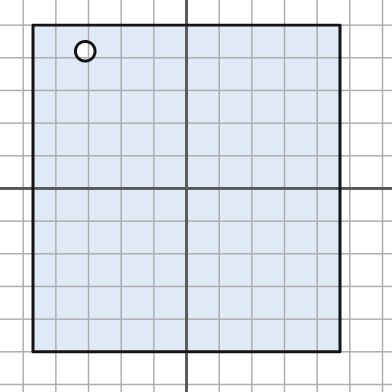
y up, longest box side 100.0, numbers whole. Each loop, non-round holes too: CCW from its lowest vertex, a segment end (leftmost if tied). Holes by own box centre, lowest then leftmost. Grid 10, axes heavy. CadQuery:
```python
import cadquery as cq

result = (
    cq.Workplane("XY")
    .moveTo(-47.0, -50.0)
    .lineTo(47.0, -50.0)
    .lineTo(47.0, 50.0)
    .lineTo(-47.0, 50.0)
    .close()
    .moveTo(-31.0, 42.0)
    .circle(3.0)
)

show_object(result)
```